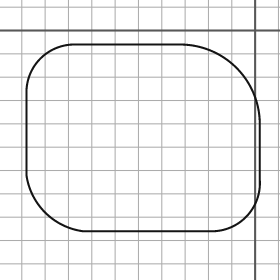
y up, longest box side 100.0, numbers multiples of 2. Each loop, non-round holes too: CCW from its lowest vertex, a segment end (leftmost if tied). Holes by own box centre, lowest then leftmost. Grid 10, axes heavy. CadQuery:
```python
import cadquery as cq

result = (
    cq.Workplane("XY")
    .moveTo(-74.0, -86.0)
    .lineTo(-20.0, -86.0)
    .threePointArc((-4.0, -80.0), (2.0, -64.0))
    .lineTo(2.0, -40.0)
    .threePointArc((-8.0, -16.0), (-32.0, -6.0))
    .lineTo(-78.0, -6.0)
    .threePointArc((-92.0, -12.0), (-98.0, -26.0))
    .lineTo(-98.0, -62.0)
    .threePointArc((-90.0, -78.0), (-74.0, -86.0))
    .close()
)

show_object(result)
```